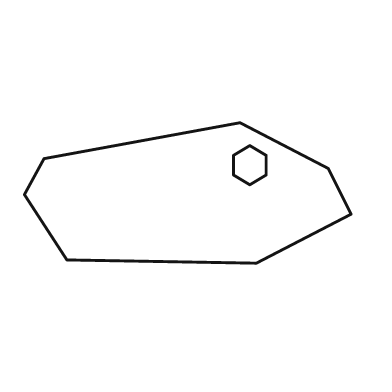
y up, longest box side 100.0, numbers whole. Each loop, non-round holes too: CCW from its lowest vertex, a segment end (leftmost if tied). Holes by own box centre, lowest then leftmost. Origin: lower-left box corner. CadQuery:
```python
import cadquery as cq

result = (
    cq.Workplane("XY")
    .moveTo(71.0, 0.0)
    .lineTo(100.0, 15.0)
    .lineTo(93.0, 29.0)
    .lineTo(66.0, 43.0)
    .lineTo(6.0, 32.0)
    .lineTo(0.0, 21.0)
    .lineTo(13.0, 1.0)
    .close()
    .moveTo(69.0, 24.0)
    .lineTo(74.0, 27.0)
    .lineTo(74.0, 33.0)
    .lineTo(69.0, 36.0)
    .lineTo(64.0, 33.0)
    .lineTo(64.0, 27.0)
    .close()
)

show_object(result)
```